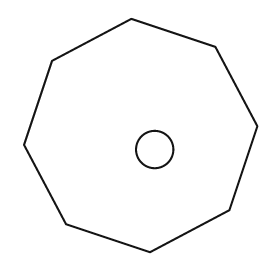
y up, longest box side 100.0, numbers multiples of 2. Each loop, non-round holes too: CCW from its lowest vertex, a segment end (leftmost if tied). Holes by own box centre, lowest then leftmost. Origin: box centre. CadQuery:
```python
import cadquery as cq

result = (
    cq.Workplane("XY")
    .moveTo(4.0, -50.0)
    .lineTo(38.0, -32.0)
    .lineTo(50.0, 4.0)
    .lineTo(32.0, 38.0)
    .lineTo(-4.0, 50.0)
    .lineTo(-38.0, 32.0)
    .lineTo(-50.0, -4.0)
    .lineTo(-32.0, -38.0)
    .close()
    .moveTo(6.0, -6.0)
    .circle(8.0)
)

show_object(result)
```